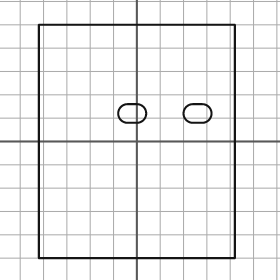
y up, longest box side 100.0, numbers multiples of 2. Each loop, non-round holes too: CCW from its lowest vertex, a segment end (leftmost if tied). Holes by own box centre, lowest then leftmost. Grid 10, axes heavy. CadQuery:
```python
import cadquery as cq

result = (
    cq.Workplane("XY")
    .moveTo(-42.0, -50.0)
    .lineTo(42.0, -50.0)
    .lineTo(42.0, 50.0)
    .lineTo(-42.0, 50.0)
    .close()
    .moveTo(-4.0, 8.0)
    .lineTo(0.0, 8.0)
    .threePointArc((4.0, 12.0), (0.0, 16.0))
    .lineTo(-4.0, 16.0)
    .threePointArc((-8.0, 12.0), (-4.0, 8.0))
    .close()
    .moveTo(24.0, 8.0)
    .lineTo(28.0, 8.0)
    .threePointArc((32.0, 12.0), (28.0, 16.0))
    .lineTo(24.0, 16.0)
    .threePointArc((20.0, 12.0), (24.0, 8.0))
    .close()
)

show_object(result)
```